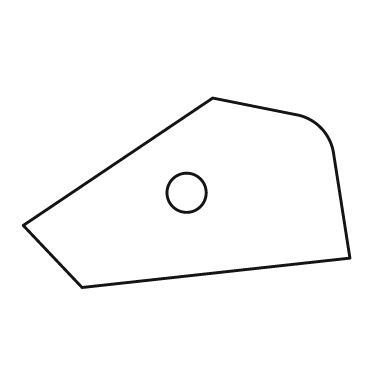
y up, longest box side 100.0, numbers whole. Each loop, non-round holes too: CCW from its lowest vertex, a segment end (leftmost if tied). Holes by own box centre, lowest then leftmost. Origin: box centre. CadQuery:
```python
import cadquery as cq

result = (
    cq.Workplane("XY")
    .moveTo(-32.0, -29.0)
    .lineTo(50.0, -20.0)
    .lineTo(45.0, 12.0)
    .threePointArc((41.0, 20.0), (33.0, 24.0))
    .lineTo(8.0, 29.0)
    .lineTo(-50.0, -10.0)
    .close()
    .moveTo(0.0, 0.0)
    .circle(6.0)
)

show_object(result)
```